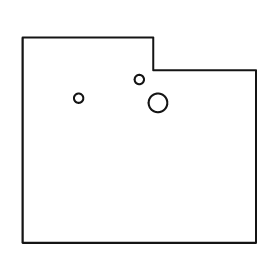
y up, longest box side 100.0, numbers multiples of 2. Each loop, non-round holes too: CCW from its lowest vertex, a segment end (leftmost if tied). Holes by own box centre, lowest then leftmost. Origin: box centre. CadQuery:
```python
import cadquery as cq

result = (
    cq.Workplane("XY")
    .moveTo(-50.0, -44.0)
    .lineTo(50.0, -44.0)
    .lineTo(50.0, 30.0)
    .lineTo(6.0, 30.0)
    .lineTo(6.0, 44.0)
    .lineTo(-50.0, 44.0)
    .close()
    .moveTo(8.0, 16.0)
    .circle(4.0)
    .moveTo(-26.0, 18.0)
    .circle(2.0)
    .moveTo(0.0, 26.0)
    .circle(2.0)
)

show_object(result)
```